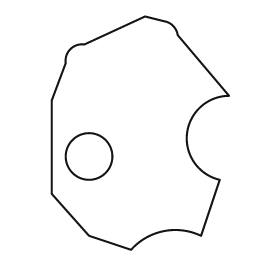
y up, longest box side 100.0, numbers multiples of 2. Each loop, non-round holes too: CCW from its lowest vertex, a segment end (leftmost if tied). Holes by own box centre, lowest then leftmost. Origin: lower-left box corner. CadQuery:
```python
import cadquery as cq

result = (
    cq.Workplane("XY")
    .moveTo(34.0, 0.0)
    .threePointArc((48.0, 8.0), (64.0, 6.0))
    .lineTo(72.0, 30.0)
    .threePointArc((58.0, 50.0), (76.0, 66.0))
    .lineTo(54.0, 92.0)
    .threePointArc((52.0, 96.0), (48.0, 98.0))
    .lineTo(40.0, 100.0)
    .lineTo(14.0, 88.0)
    .threePointArc((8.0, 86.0), (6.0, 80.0))
    .lineTo(0.0, 64.0)
    .lineTo(0.0, 24.0)
    .lineTo(16.0, 6.0)
    .close()
    .moveTo(16.0, 40.0)
    .circle(10.0)
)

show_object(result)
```